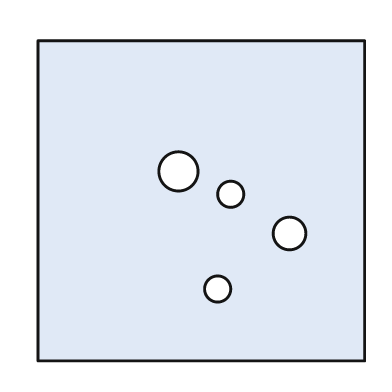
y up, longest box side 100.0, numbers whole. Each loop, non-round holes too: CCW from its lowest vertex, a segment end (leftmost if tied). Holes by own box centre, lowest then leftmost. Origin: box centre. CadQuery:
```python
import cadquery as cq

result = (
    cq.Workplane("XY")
    .moveTo(-50.0, -49.0)
    .lineTo(50.0, -49.0)
    .lineTo(50.0, 49.0)
    .lineTo(-50.0, 49.0)
    .close()
    .moveTo(5.0, -27.0)
    .circle(4.0)
    .moveTo(27.0, -10.0)
    .circle(5.0)
    .moveTo(9.0, 2.0)
    .circle(4.0)
    .moveTo(-7.0, 9.0)
    .circle(6.0)
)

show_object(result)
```